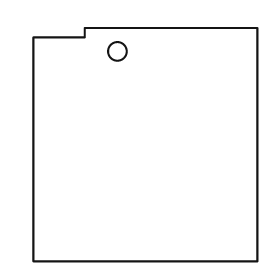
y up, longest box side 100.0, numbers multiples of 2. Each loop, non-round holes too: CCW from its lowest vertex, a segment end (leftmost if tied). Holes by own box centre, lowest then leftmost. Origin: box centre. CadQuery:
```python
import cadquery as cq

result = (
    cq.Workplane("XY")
    .moveTo(-48.0, -50.0)
    .lineTo(48.0, -50.0)
    .lineTo(48.0, 50.0)
    .lineTo(-26.0, 50.0)
    .lineTo(-26.0, 46.0)
    .lineTo(-48.0, 46.0)
    .close()
    .moveTo(-12.0, 40.0)
    .circle(4.0)
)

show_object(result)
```